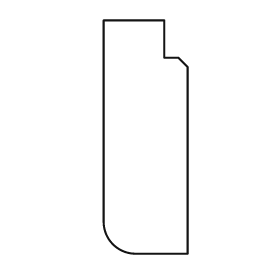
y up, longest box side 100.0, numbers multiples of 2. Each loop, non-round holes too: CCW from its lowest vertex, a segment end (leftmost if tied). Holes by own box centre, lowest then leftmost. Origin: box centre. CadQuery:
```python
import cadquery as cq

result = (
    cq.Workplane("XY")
    .moveTo(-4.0, -50.0)
    .lineTo(18.0, -50.0)
    .lineTo(18.0, 30.0)
    .lineTo(14.0, 34.0)
    .lineTo(8.0, 34.0)
    .lineTo(8.0, 50.0)
    .lineTo(-18.0, 50.0)
    .lineTo(-18.0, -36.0)
    .threePointArc((-14.0, -46.0), (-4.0, -50.0))
    .close()
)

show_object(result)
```